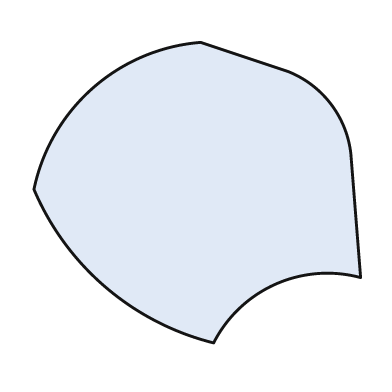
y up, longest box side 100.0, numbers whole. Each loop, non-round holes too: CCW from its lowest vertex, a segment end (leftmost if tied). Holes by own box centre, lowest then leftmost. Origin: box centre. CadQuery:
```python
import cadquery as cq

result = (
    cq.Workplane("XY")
    .moveTo(5.0, -46.0)
    .threePointArc((24.0, -28.0), (50.0, -26.0))
    .lineTo(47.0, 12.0)
    .threePointArc((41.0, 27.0), (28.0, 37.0))
    .lineTo(1.0, 46.0)
    .threePointArc((-32.0, 32.0), (-50.0, 1.0))
    .threePointArc((-28.0, -29.0), (5.0, -46.0))
    .close()
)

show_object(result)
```